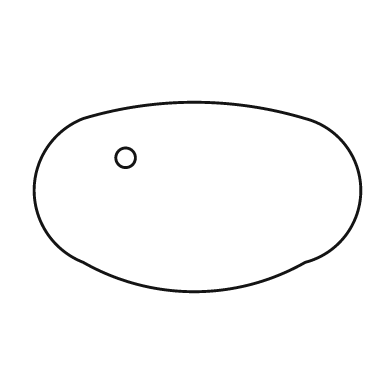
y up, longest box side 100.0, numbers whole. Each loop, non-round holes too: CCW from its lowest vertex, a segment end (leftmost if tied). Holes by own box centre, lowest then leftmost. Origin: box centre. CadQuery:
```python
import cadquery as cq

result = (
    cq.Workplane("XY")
    .moveTo(-35.0, -20.0)
    .threePointArc((-1.0, -29.0), (33.0, -20.0))
    .threePointArc((50.0, 2.0), (33.0, 24.0))
    .threePointArc((-1.0, 29.0), (-35.0, 24.0))
    .threePointArc((-50.0, 2.0), (-35.0, -20.0))
    .close()
    .moveTo(-22.0, 12.0)
    .circle(3.0)
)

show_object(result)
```